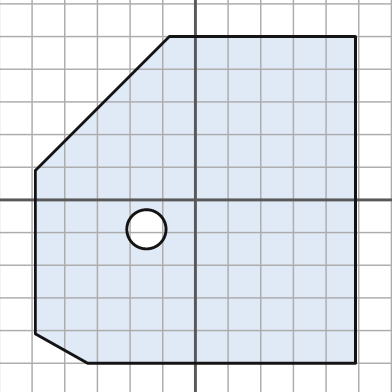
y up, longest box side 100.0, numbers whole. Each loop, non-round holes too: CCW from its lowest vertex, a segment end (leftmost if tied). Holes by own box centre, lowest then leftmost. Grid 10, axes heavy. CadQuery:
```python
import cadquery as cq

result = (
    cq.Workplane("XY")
    .moveTo(-33.0, -50.0)
    .lineTo(49.0, -50.0)
    .lineTo(49.0, 50.0)
    .lineTo(-8.0, 50.0)
    .lineTo(-49.0, 9.0)
    .lineTo(-49.0, -41.0)
    .close()
    .moveTo(-15.0, -9.0)
    .circle(6.0)
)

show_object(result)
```